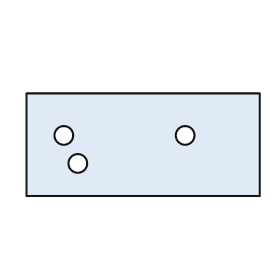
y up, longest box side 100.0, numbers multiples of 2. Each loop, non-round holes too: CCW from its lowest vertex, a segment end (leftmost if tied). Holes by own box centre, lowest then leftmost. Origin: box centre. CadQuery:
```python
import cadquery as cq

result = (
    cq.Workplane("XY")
    .moveTo(-50.0, -22.0)
    .lineTo(50.0, -22.0)
    .lineTo(50.0, 22.0)
    .lineTo(-50.0, 22.0)
    .close()
    .moveTo(-28.0, -8.0)
    .circle(4.0)
    .moveTo(-34.0, 4.0)
    .circle(4.0)
    .moveTo(18.0, 4.0)
    .circle(4.0)
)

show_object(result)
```